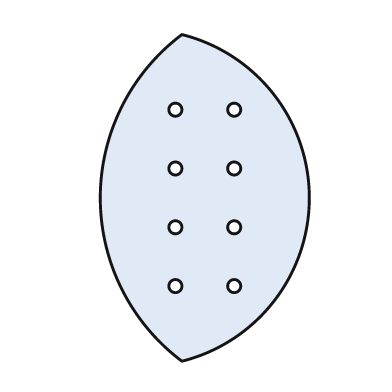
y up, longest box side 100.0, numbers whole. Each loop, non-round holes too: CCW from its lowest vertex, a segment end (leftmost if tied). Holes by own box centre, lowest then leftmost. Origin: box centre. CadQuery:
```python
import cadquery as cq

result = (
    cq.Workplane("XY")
    .moveTo(-7.0, -50.0)
    .threePointArc((32.0, 0.0), (-7.0, 50.0))
    .threePointArc((-32.0, 0.0), (-7.0, -50.0))
    .close()
    .moveTo(-9.0, -27.0)
    .circle(2.0)
    .moveTo(9.0, -27.0)
    .circle(2.0)
    .moveTo(-9.0, -9.0)
    .circle(2.0)
    .moveTo(9.0, -9.0)
    .circle(2.0)
    .moveTo(-9.0, 9.0)
    .circle(2.0)
    .moveTo(9.0, 9.0)
    .circle(2.0)
    .moveTo(-9.0, 27.0)
    .circle(2.0)
    .moveTo(9.0, 27.0)
    .circle(2.0)
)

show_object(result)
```